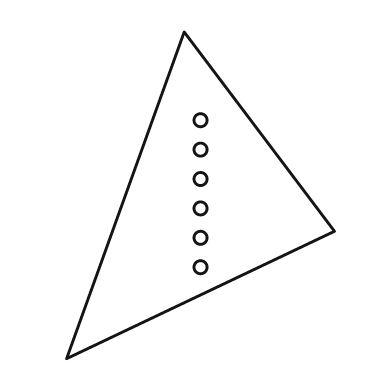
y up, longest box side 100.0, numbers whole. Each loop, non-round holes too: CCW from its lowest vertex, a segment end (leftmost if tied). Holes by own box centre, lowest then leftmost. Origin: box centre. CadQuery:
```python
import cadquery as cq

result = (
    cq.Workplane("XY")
    .moveTo(-41.0, -50.0)
    .lineTo(41.0, -11.0)
    .lineTo(-5.0, 50.0)
    .close()
    .moveTo(0.0, -22.0)
    .circle(2.0)
    .moveTo(0.0, -13.0)
    .circle(2.0)
    .moveTo(0.0, -4.0)
    .circle(2.0)
    .moveTo(0.0, 5.0)
    .circle(2.0)
    .moveTo(0.0, 14.0)
    .circle(2.0)
    .moveTo(0.0, 23.0)
    .circle(2.0)
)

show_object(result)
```